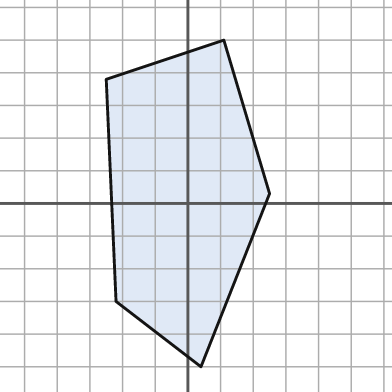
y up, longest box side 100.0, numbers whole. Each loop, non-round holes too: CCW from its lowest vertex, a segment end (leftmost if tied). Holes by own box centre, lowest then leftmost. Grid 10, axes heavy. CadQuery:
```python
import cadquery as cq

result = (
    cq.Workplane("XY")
    .moveTo(4.0, -50.0)
    .lineTo(25.0, 3.0)
    .lineTo(11.0, 50.0)
    .lineTo(-25.0, 38.0)
    .lineTo(-22.0, -30.0)
    .close()
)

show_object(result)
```